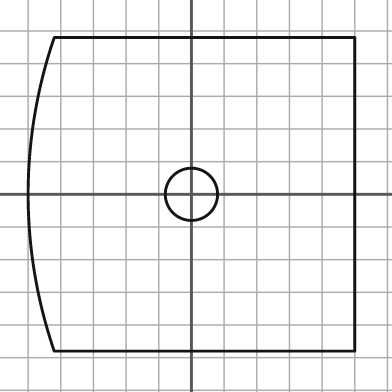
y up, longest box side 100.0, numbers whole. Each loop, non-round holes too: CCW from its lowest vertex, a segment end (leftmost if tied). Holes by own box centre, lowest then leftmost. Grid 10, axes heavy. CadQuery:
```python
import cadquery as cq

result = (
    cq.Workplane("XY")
    .moveTo(-42.0, -48.0)
    .lineTo(50.0, -48.0)
    .lineTo(50.0, 48.0)
    .lineTo(-42.0, 48.0)
    .threePointArc((-50.0, 0.0), (-42.0, -48.0))
    .close()
    .moveTo(0.0, 0.0)
    .circle(8.0)
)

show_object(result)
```